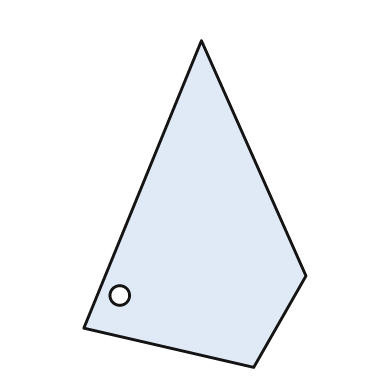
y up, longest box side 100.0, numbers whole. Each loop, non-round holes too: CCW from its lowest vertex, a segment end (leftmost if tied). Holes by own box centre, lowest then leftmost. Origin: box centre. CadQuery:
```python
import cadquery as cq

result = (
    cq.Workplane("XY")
    .moveTo(18.0, -50.0)
    .lineTo(34.0, -22.0)
    .lineTo(2.0, 50.0)
    .lineTo(-34.0, -38.0)
    .close()
    .moveTo(-23.0, -28.0)
    .circle(3.0)
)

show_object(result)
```